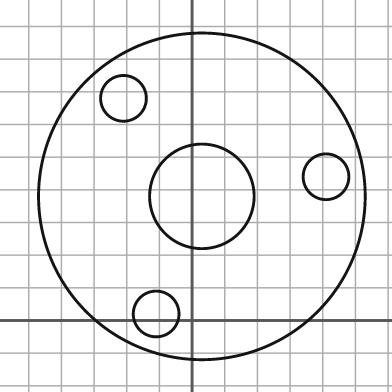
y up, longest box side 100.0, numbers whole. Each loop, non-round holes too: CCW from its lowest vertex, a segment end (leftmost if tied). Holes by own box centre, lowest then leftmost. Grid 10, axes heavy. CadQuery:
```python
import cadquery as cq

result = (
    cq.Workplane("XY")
    .moveTo(3.0, 38.0)
    .circle(50.0)
    .moveTo(-11.0, 2.0)
    .circle(7.0)
    .moveTo(3.0, 38.0)
    .circle(16.0)
    .moveTo(41.0, 44.0)
    .circle(7.0)
    .moveTo(-21.0, 68.0)
    .circle(7.0)
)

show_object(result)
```